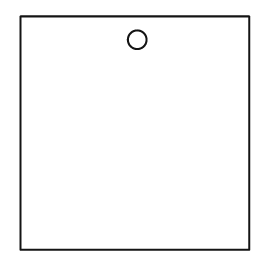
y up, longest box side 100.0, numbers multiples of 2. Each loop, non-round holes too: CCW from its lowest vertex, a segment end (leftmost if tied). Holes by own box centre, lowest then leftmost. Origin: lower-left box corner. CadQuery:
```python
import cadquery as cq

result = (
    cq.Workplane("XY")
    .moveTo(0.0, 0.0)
    .lineTo(98.0, 0.0)
    .lineTo(98.0, 100.0)
    .lineTo(0.0, 100.0)
    .close()
    .moveTo(50.0, 90.0)
    .circle(4.0)
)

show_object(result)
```